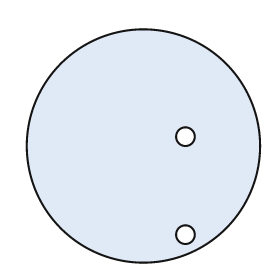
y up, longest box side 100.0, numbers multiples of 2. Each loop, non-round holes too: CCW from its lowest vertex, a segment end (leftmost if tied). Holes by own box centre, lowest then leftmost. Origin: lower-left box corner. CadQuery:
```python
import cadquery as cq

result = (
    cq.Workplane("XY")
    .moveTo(50.0, 50.0)
    .circle(50.0)
    .moveTo(68.0, 12.0)
    .circle(4.0)
    .moveTo(68.0, 54.0)
    .circle(4.0)
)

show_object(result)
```